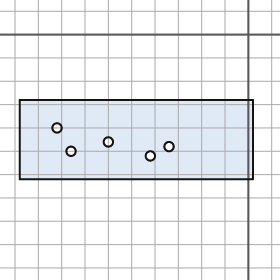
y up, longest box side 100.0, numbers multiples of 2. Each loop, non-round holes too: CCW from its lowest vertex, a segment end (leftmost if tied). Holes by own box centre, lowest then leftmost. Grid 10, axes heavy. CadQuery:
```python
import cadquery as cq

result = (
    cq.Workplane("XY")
    .moveTo(-98.0, -62.0)
    .lineTo(2.0, -62.0)
    .lineTo(2.0, -28.0)
    .lineTo(-98.0, -28.0)
    .close()
    .moveTo(-42.0, -52.0)
    .circle(2.0)
    .moveTo(-76.0, -50.0)
    .circle(2.0)
    .moveTo(-34.0, -48.0)
    .circle(2.0)
    .moveTo(-60.0, -46.0)
    .circle(2.0)
    .moveTo(-82.0, -40.0)
    .circle(2.0)
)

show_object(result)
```